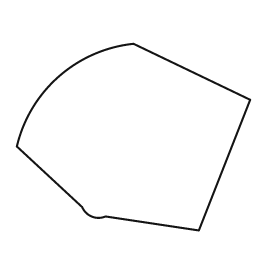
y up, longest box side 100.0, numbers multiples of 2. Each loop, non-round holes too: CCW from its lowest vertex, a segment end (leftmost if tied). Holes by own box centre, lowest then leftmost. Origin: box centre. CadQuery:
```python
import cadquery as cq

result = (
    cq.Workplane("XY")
    .moveTo(28.0, -40.0)
    .lineTo(50.0, 16.0)
    .lineTo(0.0, 40.0)
    .threePointArc((-32.0, 26.0), (-50.0, -4.0))
    .lineTo(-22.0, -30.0)
    .threePointArc((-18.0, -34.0), (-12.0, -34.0))
    .close()
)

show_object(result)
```